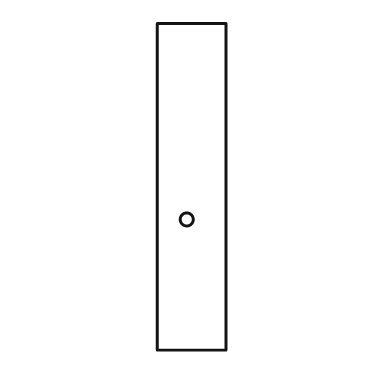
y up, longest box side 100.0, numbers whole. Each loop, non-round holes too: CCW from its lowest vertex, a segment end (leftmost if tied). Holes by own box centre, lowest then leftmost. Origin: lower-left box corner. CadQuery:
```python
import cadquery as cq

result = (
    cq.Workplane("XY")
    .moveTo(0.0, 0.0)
    .lineTo(21.0, 0.0)
    .lineTo(21.0, 100.0)
    .lineTo(0.0, 100.0)
    .close()
    .moveTo(9.0, 40.0)
    .circle(2.0)
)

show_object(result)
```